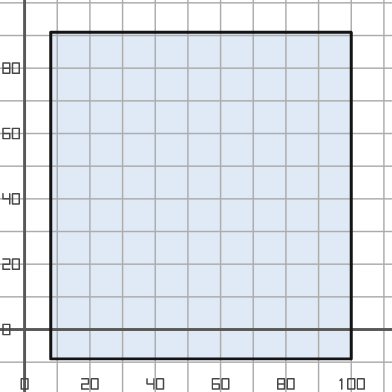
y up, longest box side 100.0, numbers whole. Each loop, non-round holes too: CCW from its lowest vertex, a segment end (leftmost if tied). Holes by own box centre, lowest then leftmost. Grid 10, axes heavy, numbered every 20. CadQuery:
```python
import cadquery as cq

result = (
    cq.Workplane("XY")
    .moveTo(8.0, -9.0)
    .lineTo(100.0, -9.0)
    .lineTo(100.0, 91.0)
    .lineTo(8.0, 91.0)
    .close()
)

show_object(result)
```